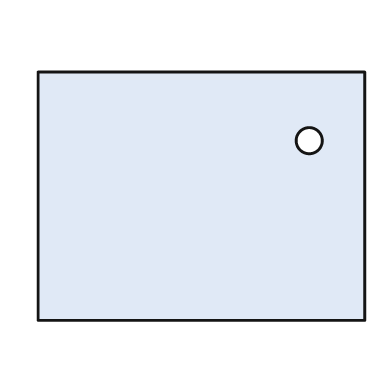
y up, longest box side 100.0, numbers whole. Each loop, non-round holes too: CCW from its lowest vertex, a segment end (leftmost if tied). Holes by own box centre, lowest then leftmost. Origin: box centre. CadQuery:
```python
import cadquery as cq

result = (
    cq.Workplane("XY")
    .moveTo(-50.0, -38.0)
    .lineTo(50.0, -38.0)
    .lineTo(50.0, 38.0)
    .lineTo(-50.0, 38.0)
    .close()
    .moveTo(33.0, 17.0)
    .circle(4.0)
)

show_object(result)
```